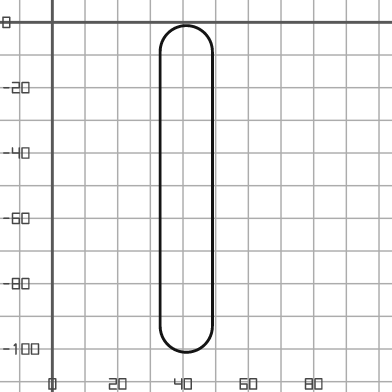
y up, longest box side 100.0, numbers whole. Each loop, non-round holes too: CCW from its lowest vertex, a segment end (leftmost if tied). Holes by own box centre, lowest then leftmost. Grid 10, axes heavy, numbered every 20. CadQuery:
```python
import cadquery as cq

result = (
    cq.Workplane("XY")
    .moveTo(33.0, -93.0)
    .threePointArc((41.0, -101.0), (49.0, -93.0))
    .lineTo(49.0, -9.0)
    .threePointArc((41.0, -1.0), (33.0, -9.0))
    .close()
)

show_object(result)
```